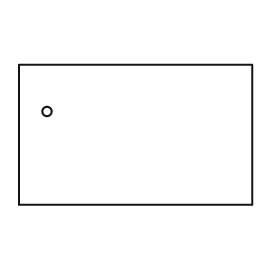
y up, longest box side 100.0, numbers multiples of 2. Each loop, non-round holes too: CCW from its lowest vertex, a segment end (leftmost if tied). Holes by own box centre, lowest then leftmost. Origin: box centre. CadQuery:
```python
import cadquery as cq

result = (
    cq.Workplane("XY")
    .moveTo(-50.0, -30.0)
    .lineTo(50.0, -30.0)
    .lineTo(50.0, 30.0)
    .lineTo(-50.0, 30.0)
    .close()
    .moveTo(-38.0, 10.0)
    .circle(2.0)
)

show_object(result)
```